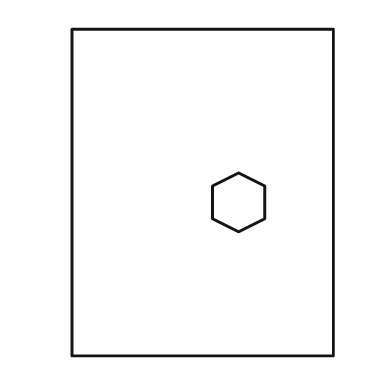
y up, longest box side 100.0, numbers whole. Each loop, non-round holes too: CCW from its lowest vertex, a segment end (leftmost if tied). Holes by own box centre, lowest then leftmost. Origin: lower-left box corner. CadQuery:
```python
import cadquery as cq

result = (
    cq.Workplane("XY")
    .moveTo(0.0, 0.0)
    .lineTo(80.0, 0.0)
    .lineTo(80.0, 100.0)
    .lineTo(0.0, 100.0)
    .close()
    .moveTo(51.0, 38.0)
    .lineTo(59.0, 42.0)
    .lineTo(59.0, 52.0)
    .lineTo(51.0, 56.0)
    .lineTo(43.0, 52.0)
    .lineTo(43.0, 42.0)
    .close()
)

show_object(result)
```